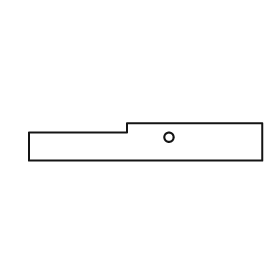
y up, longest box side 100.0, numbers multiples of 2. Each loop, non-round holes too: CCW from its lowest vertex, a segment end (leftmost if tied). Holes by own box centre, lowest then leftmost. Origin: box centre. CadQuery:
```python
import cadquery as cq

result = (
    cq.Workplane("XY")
    .moveTo(-50.0, -8.0)
    .lineTo(50.0, -8.0)
    .lineTo(50.0, 8.0)
    .lineTo(-8.0, 8.0)
    .lineTo(-8.0, 4.0)
    .lineTo(-50.0, 4.0)
    .close()
    .moveTo(10.0, 2.0)
    .circle(2.0)
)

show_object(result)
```